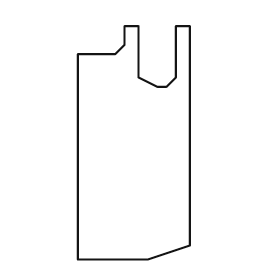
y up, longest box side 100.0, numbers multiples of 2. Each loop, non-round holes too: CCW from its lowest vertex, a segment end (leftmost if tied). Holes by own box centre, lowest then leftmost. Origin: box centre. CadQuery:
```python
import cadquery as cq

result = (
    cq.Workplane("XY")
    .moveTo(-24.0, -50.0)
    .lineTo(6.0, -50.0)
    .lineTo(24.0, -44.0)
    .lineTo(24.0, 50.0)
    .lineTo(18.0, 50.0)
    .lineTo(18.0, 28.0)
    .lineTo(14.0, 24.0)
    .lineTo(10.0, 24.0)
    .lineTo(2.0, 28.0)
    .lineTo(2.0, 50.0)
    .lineTo(-4.0, 50.0)
    .lineTo(-4.0, 42.0)
    .lineTo(-8.0, 38.0)
    .lineTo(-24.0, 38.0)
    .close()
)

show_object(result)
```